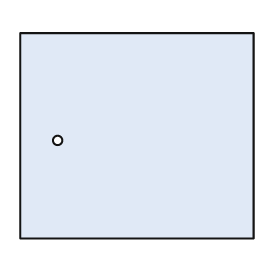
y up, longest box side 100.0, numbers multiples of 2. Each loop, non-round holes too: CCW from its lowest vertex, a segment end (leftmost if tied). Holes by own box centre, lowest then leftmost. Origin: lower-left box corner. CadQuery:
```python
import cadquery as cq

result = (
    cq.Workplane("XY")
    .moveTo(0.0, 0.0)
    .lineTo(100.0, 0.0)
    .lineTo(100.0, 88.0)
    .lineTo(0.0, 88.0)
    .close()
    .moveTo(16.0, 42.0)
    .circle(2.0)
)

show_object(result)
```